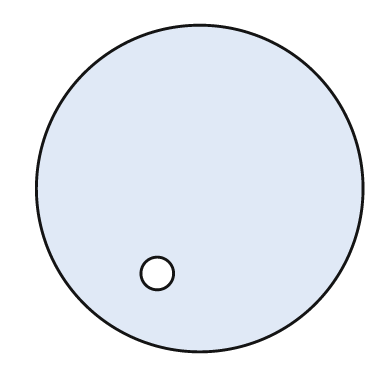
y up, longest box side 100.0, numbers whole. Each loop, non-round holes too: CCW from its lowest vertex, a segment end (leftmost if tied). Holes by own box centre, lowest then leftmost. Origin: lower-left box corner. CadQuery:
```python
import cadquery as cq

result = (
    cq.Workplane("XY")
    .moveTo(50.0, 50.0)
    .circle(50.0)
    .moveTo(37.0, 24.0)
    .circle(5.0)
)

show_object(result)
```